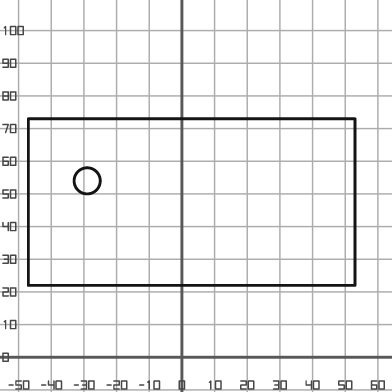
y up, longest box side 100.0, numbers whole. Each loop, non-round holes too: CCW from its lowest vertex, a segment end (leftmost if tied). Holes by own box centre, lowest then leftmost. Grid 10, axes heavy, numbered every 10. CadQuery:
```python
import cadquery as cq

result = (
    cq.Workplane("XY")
    .moveTo(-47.0, 22.0)
    .lineTo(53.0, 22.0)
    .lineTo(53.0, 73.0)
    .lineTo(-47.0, 73.0)
    .close()
    .moveTo(-29.0, 54.0)
    .circle(4.0)
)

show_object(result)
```